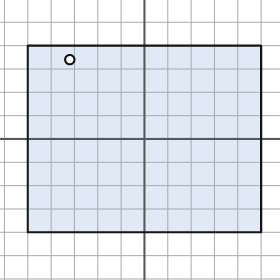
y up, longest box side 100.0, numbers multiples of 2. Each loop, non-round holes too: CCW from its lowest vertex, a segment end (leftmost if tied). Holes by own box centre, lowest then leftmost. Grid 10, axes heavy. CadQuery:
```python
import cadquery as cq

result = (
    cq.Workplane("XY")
    .moveTo(-50.0, -40.0)
    .lineTo(50.0, -40.0)
    .lineTo(50.0, 40.0)
    .lineTo(-50.0, 40.0)
    .close()
    .moveTo(-32.0, 34.0)
    .circle(2.0)
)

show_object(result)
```